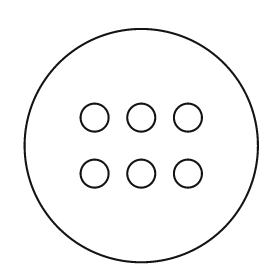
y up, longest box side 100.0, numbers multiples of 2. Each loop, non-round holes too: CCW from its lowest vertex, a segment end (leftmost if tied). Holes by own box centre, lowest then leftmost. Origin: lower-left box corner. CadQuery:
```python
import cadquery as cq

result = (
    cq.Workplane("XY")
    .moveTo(50.0, 50.0)
    .circle(50.0)
    .moveTo(30.0, 38.0)
    .circle(6.0)
    .moveTo(50.0, 38.0)
    .circle(6.0)
    .moveTo(70.0, 38.0)
    .circle(6.0)
    .moveTo(30.0, 62.0)
    .circle(6.0)
    .moveTo(50.0, 62.0)
    .circle(6.0)
    .moveTo(70.0, 62.0)
    .circle(6.0)
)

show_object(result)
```